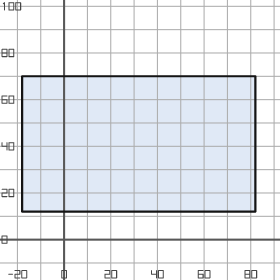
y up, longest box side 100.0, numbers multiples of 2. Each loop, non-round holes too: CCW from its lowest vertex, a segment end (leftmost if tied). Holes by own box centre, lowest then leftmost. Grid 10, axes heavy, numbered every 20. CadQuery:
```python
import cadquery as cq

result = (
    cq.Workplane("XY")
    .moveTo(-18.0, 12.0)
    .lineTo(82.0, 12.0)
    .lineTo(82.0, 70.0)
    .lineTo(-18.0, 70.0)
    .close()
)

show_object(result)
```